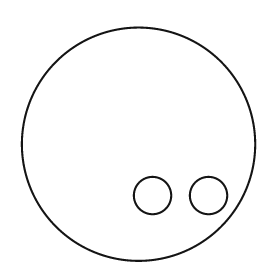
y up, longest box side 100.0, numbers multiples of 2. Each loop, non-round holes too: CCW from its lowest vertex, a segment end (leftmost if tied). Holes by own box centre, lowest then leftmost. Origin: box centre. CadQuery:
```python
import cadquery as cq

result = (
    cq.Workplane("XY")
    .moveTo(0.0, 0.0)
    .circle(50.0)
    .moveTo(6.0, -22.0)
    .circle(8.0)
    .moveTo(30.0, -22.0)
    .circle(8.0)
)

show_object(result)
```